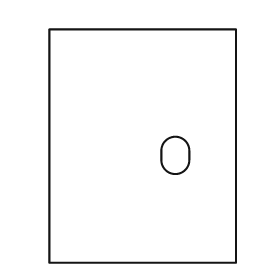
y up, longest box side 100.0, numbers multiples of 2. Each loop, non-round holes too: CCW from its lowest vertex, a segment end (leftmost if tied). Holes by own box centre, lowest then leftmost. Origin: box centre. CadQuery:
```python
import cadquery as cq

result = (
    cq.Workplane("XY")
    .moveTo(-40.0, -50.0)
    .lineTo(40.0, -50.0)
    .lineTo(40.0, 50.0)
    .lineTo(-40.0, 50.0)
    .close()
    .moveTo(8.0, -6.0)
    .threePointArc((14.0, -12.0), (20.0, -6.0))
    .lineTo(20.0, -2.0)
    .threePointArc((14.0, 4.0), (8.0, -2.0))
    .close()
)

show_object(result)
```